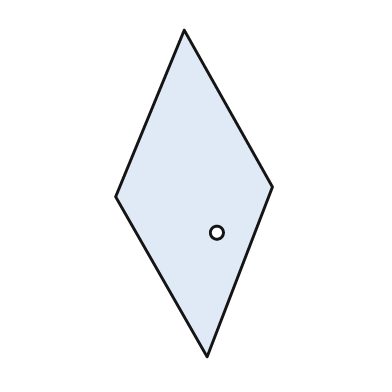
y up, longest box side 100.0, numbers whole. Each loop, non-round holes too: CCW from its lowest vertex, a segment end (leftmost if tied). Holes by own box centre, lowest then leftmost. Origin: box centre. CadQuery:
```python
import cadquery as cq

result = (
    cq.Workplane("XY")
    .moveTo(4.0, -50.0)
    .lineTo(24.0, 2.0)
    .lineTo(-3.0, 50.0)
    .lineTo(-24.0, -1.0)
    .close()
    .moveTo(7.0, -12.0)
    .circle(2.0)
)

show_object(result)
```